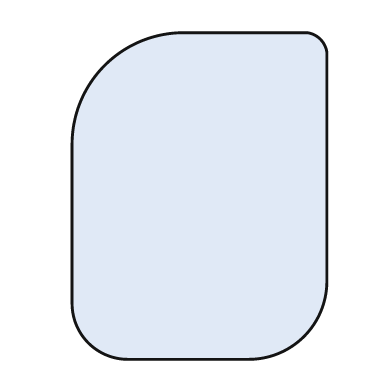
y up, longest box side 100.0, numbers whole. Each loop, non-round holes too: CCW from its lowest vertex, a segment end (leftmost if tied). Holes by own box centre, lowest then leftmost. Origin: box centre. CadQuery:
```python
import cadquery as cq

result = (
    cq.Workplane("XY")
    .moveTo(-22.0, -50.0)
    .lineTo(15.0, -50.0)
    .threePointArc((32.0, -43.0), (39.0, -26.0))
    .lineTo(39.0, 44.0)
    .threePointArc((37.0, 48.0), (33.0, 50.0))
    .lineTo(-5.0, 50.0)
    .threePointArc((-29.0, 40.0), (-39.0, 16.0))
    .lineTo(-39.0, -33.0)
    .threePointArc((-34.0, -45.0), (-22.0, -50.0))
    .close()
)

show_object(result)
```